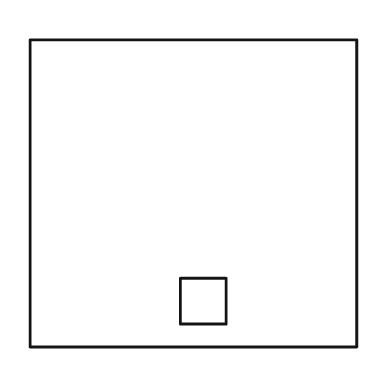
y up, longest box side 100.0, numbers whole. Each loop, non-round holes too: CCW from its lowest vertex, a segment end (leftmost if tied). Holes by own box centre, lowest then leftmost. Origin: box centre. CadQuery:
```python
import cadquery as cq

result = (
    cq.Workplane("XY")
    .moveTo(-50.0, -47.0)
    .lineTo(50.0, -47.0)
    .lineTo(50.0, 47.0)
    .lineTo(-50.0, 47.0)
    .close()
    .moveTo(-4.0, -40.0)
    .lineTo(10.0, -40.0)
    .lineTo(10.0, -26.0)
    .lineTo(-4.0, -26.0)
    .close()
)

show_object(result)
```